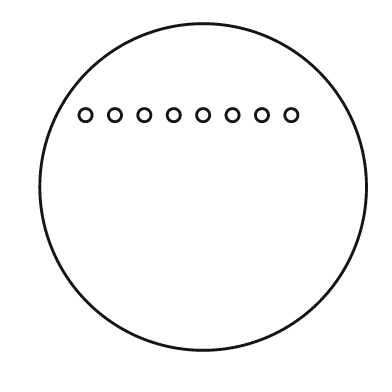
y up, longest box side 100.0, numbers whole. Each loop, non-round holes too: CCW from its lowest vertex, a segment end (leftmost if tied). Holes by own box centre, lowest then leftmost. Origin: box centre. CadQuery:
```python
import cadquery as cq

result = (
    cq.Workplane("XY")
    .moveTo(0.0, 0.0)
    .circle(50.0)
    .moveTo(-36.0, 22.0)
    .circle(2.0)
    .moveTo(-27.0, 22.0)
    .circle(2.0)
    .moveTo(-18.0, 22.0)
    .circle(2.0)
    .moveTo(-9.0, 22.0)
    .circle(2.0)
    .moveTo(0.0, 22.0)
    .circle(2.0)
    .moveTo(9.0, 22.0)
    .circle(2.0)
    .moveTo(18.0, 22.0)
    .circle(2.0)
    .moveTo(27.0, 22.0)
    .circle(2.0)
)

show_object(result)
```